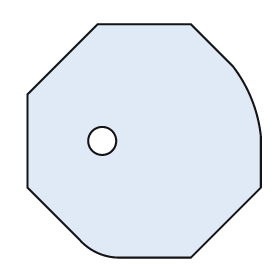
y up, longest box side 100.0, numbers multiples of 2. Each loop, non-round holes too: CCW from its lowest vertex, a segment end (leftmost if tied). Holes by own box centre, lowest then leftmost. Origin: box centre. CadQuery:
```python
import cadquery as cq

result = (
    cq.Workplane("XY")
    .moveTo(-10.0, -50.0)
    .lineTo(20.0, -50.0)
    .lineTo(50.0, -20.0)
    .lineTo(50.0, 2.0)
    .threePointArc((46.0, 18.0), (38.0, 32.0))
    .lineTo(20.0, 50.0)
    .lineTo(-20.0, 50.0)
    .lineTo(-50.0, 20.0)
    .lineTo(-50.0, -20.0)
    .lineTo(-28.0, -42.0)
    .threePointArc((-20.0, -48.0), (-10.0, -50.0))
    .close()
    .moveTo(-18.0, 0.0)
    .circle(6.0)
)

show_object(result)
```